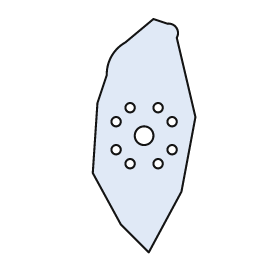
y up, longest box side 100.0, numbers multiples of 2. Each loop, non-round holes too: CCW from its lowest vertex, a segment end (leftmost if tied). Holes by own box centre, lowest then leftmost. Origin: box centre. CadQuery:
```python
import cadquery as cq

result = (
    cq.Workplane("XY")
    .moveTo(2.0, -50.0)
    .lineTo(16.0, -24.0)
    .lineTo(22.0, 8.0)
    .lineTo(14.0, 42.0)
    .threePointArc((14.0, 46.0), (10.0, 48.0))
    .lineTo(4.0, 50.0)
    .lineTo(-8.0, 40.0)
    .threePointArc((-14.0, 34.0), (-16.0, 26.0))
    .lineTo(-20.0, 14.0)
    .lineTo(-22.0, -16.0)
    .lineTo(-10.0, -38.0)
    .close()
    .moveTo(-6.0, -12.0)
    .circle(2.0)
    .moveTo(6.0, -12.0)
    .circle(2.0)
    .moveTo(-12.0, -6.0)
    .circle(2.0)
    .moveTo(12.0, -6.0)
    .circle(2.0)
    .moveTo(0.0, 0.0)
    .circle(4.0)
    .moveTo(-12.0, 6.0)
    .circle(2.0)
    .moveTo(12.0, 6.0)
    .circle(2.0)
    .moveTo(-6.0, 12.0)
    .circle(2.0)
    .moveTo(6.0, 12.0)
    .circle(2.0)
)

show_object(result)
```